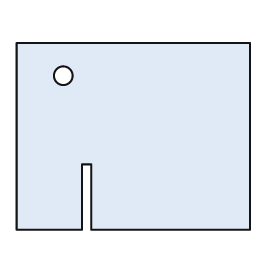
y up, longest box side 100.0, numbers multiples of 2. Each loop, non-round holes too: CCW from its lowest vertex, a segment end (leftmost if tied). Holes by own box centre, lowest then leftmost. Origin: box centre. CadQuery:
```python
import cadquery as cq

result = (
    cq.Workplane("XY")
    .moveTo(-50.0, -40.0)
    .lineTo(-22.0, -40.0)
    .lineTo(-22.0, -12.0)
    .lineTo(-18.0, -12.0)
    .lineTo(-18.0, -40.0)
    .lineTo(50.0, -40.0)
    .lineTo(50.0, 40.0)
    .lineTo(-50.0, 40.0)
    .close()
    .moveTo(-30.0, 26.0)
    .circle(4.0)
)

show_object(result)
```